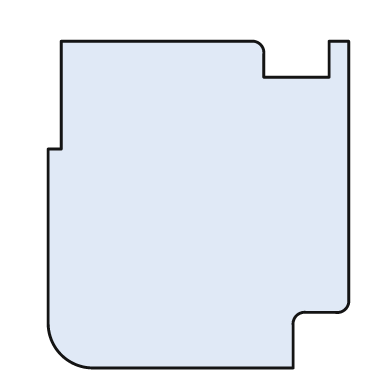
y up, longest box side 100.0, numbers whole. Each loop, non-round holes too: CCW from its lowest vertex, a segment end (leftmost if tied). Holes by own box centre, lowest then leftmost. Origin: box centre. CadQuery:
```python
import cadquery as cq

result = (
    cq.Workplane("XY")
    .moveTo(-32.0, -50.0)
    .lineTo(29.0, -50.0)
    .lineTo(29.0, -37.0)
    .threePointArc((30.0, -34.0), (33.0, -33.0))
    .lineTo(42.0, -33.0)
    .threePointArc((45.0, -32.0), (46.0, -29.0))
    .lineTo(46.0, 50.0)
    .lineTo(40.0, 50.0)
    .lineTo(40.0, 39.0)
    .lineTo(20.0, 39.0)
    .lineTo(20.0, 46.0)
    .threePointArc((19.0, 49.0), (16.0, 50.0))
    .lineTo(-42.0, 50.0)
    .lineTo(-42.0, 17.0)
    .lineTo(-46.0, 17.0)
    .lineTo(-46.0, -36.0)
    .threePointArc((-42.0, -46.0), (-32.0, -50.0))
    .close()
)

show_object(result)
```